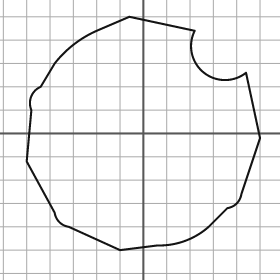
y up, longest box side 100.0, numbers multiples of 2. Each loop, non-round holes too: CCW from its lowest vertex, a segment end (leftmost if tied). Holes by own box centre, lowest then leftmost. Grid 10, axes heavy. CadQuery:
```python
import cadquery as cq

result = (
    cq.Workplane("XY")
    .moveTo(-10.0, -50.0)
    .lineTo(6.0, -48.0)
    .threePointArc((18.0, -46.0), (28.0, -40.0))
    .lineTo(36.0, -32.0)
    .threePointArc((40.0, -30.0), (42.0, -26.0))
    .lineTo(50.0, -2.0)
    .lineTo(44.0, 26.0)
    .threePointArc((26.0, 26.0), (22.0, 44.0))
    .lineTo(-6.0, 50.0)
    .lineTo(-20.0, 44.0)
    .threePointArc((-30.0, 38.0), (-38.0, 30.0))
    .lineTo(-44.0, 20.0)
    .threePointArc((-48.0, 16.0), (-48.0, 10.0))
    .lineTo(-50.0, -12.0)
    .lineTo(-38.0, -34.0)
    .threePointArc((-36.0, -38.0), (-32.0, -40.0))
    .close()
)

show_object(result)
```